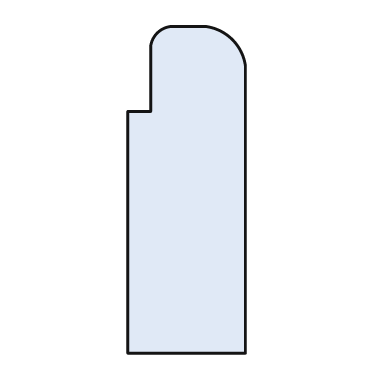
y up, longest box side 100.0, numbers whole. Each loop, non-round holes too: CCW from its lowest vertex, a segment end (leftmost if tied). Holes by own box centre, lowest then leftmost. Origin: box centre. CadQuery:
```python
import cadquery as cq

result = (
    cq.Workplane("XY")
    .moveTo(-18.0, -50.0)
    .lineTo(18.0, -50.0)
    .lineTo(18.0, 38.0)
    .threePointArc((14.0, 46.0), (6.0, 50.0))
    .lineTo(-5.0, 50.0)
    .threePointArc((-9.0, 48.0), (-11.0, 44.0))
    .lineTo(-11.0, 24.0)
    .lineTo(-18.0, 24.0)
    .close()
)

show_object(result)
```